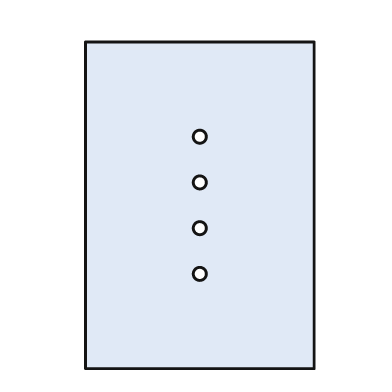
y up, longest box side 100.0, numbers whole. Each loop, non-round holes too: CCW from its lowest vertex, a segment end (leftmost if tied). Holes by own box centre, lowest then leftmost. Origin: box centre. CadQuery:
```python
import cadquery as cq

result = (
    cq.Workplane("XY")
    .moveTo(-35.0, -50.0)
    .lineTo(35.0, -50.0)
    .lineTo(35.0, 50.0)
    .lineTo(-35.0, 50.0)
    .close()
    .moveTo(0.0, -21.0)
    .circle(2.0)
    .moveTo(0.0, -7.0)
    .circle(2.0)
    .moveTo(0.0, 7.0)
    .circle(2.0)
    .moveTo(0.0, 21.0)
    .circle(2.0)
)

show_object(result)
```